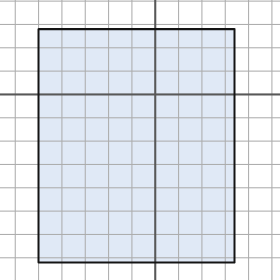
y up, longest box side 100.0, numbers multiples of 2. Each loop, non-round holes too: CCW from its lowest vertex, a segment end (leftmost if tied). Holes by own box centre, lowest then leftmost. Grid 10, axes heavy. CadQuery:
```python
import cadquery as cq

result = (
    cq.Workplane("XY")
    .moveTo(-50.0, -72.0)
    .lineTo(34.0, -72.0)
    .lineTo(34.0, 28.0)
    .lineTo(-50.0, 28.0)
    .close()
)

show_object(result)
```